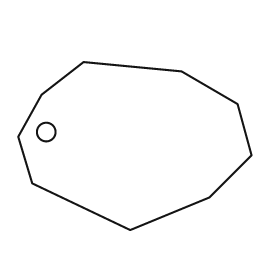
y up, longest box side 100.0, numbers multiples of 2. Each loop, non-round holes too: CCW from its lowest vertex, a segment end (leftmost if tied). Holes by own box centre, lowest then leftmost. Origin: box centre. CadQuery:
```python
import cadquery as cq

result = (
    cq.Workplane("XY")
    .moveTo(-2.0, -36.0)
    .lineTo(32.0, -22.0)
    .lineTo(50.0, -4.0)
    .lineTo(44.0, 18.0)
    .lineTo(20.0, 32.0)
    .lineTo(-22.0, 36.0)
    .lineTo(-40.0, 22.0)
    .lineTo(-50.0, 4.0)
    .lineTo(-44.0, -16.0)
    .close()
    .moveTo(-38.0, 6.0)
    .circle(4.0)
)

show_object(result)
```